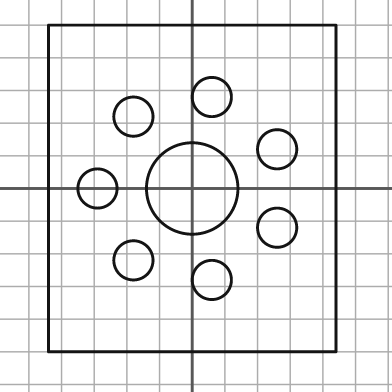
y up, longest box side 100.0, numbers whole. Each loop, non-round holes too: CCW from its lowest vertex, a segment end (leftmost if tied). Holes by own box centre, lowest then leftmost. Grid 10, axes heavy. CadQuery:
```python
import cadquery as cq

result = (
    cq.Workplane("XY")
    .moveTo(-44.0, -50.0)
    .lineTo(44.0, -50.0)
    .lineTo(44.0, 50.0)
    .lineTo(-44.0, 50.0)
    .close()
    .moveTo(6.0, -28.0)
    .circle(6.0)
    .moveTo(-18.0, -22.0)
    .circle(6.0)
    .moveTo(26.0, -12.0)
    .circle(6.0)
    .moveTo(-29.0, 0.0)
    .circle(6.0)
    .moveTo(0.0, 0.0)
    .circle(14.0)
    .moveTo(26.0, 12.0)
    .circle(6.0)
    .moveTo(-18.0, 22.0)
    .circle(6.0)
    .moveTo(6.0, 28.0)
    .circle(6.0)
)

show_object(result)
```